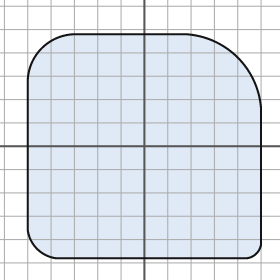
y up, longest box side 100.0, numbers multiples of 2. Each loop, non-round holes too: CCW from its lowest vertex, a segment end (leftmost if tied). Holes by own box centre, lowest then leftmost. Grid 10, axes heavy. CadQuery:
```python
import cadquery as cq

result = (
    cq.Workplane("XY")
    .moveTo(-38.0, -48.0)
    .lineTo(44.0, -48.0)
    .threePointArc((48.0, -46.0), (50.0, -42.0))
    .lineTo(50.0, 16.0)
    .threePointArc((40.0, 38.0), (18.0, 48.0))
    .lineTo(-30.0, 48.0)
    .threePointArc((-44.0, 42.0), (-50.0, 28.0))
    .lineTo(-50.0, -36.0)
    .threePointArc((-46.0, -44.0), (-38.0, -48.0))
    .close()
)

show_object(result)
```